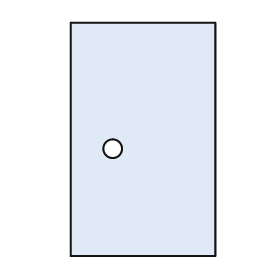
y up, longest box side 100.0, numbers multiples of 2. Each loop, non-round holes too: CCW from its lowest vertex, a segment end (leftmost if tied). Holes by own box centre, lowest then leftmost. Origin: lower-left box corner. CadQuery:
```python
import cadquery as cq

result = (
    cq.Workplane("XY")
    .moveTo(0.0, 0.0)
    .lineTo(62.0, 0.0)
    .lineTo(62.0, 100.0)
    .lineTo(0.0, 100.0)
    .close()
    .moveTo(18.0, 46.0)
    .circle(4.0)
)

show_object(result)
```